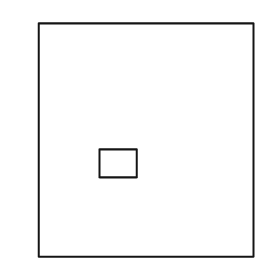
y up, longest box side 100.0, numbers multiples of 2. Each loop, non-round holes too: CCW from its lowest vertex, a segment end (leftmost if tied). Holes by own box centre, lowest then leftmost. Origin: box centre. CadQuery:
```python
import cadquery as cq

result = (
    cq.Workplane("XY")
    .moveTo(-46.0, -50.0)
    .lineTo(46.0, -50.0)
    .lineTo(46.0, 50.0)
    .lineTo(-46.0, 50.0)
    .close()
    .moveTo(-20.0, -16.0)
    .lineTo(-4.0, -16.0)
    .lineTo(-4.0, -4.0)
    .lineTo(-20.0, -4.0)
    .close()
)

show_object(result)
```